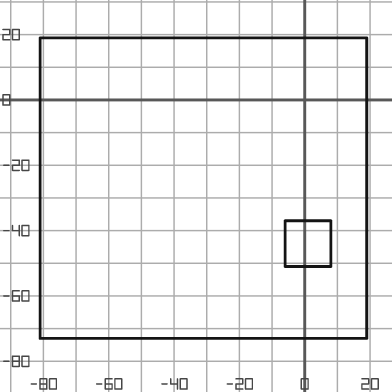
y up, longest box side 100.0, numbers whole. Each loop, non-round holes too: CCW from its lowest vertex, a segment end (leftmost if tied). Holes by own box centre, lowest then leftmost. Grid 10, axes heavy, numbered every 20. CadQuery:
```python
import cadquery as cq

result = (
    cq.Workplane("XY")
    .moveTo(-81.0, -73.0)
    .lineTo(19.0, -73.0)
    .lineTo(19.0, 19.0)
    .lineTo(-81.0, 19.0)
    .close()
    .moveTo(-6.0, -51.0)
    .lineTo(8.0, -51.0)
    .lineTo(8.0, -37.0)
    .lineTo(-6.0, -37.0)
    .close()
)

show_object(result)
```